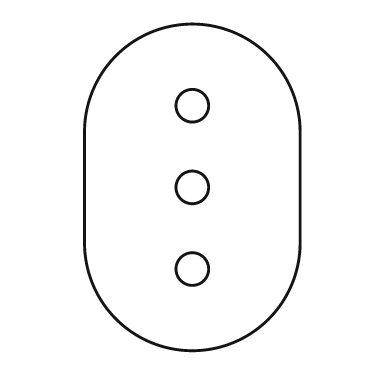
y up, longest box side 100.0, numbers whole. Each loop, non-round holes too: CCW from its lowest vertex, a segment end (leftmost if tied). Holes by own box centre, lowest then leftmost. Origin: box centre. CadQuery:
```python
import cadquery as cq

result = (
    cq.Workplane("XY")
    .moveTo(-33.0, -17.0)
    .threePointArc((0.0, -50.0), (33.0, -17.0))
    .lineTo(33.0, 17.0)
    .threePointArc((0.0, 50.0), (-33.0, 17.0))
    .close()
    .moveTo(0.0, -25.0)
    .circle(5.0)
    .moveTo(0.0, 0.0)
    .circle(5.0)
    .moveTo(0.0, 25.0)
    .circle(5.0)
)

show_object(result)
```